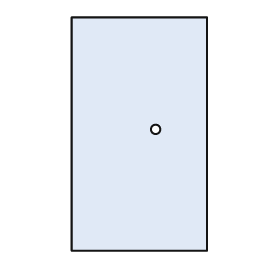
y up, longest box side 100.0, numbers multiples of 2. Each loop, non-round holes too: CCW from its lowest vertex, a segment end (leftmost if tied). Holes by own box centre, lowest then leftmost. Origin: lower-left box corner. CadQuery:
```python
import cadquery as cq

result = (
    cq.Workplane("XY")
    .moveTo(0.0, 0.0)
    .lineTo(58.0, 0.0)
    .lineTo(58.0, 100.0)
    .lineTo(0.0, 100.0)
    .close()
    .moveTo(36.0, 52.0)
    .circle(2.0)
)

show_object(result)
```